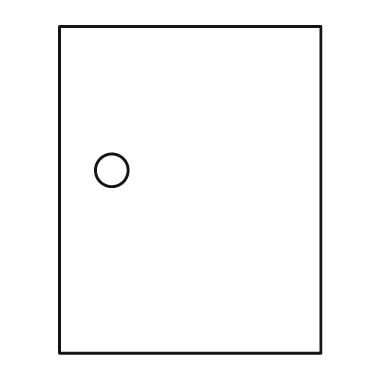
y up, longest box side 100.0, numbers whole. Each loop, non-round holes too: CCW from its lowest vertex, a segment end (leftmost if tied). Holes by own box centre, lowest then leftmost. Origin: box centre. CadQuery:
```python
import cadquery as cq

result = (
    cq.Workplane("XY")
    .moveTo(-40.0, -50.0)
    .lineTo(40.0, -50.0)
    .lineTo(40.0, 50.0)
    .lineTo(-40.0, 50.0)
    .close()
    .moveTo(-24.0, 6.0)
    .circle(5.0)
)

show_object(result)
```